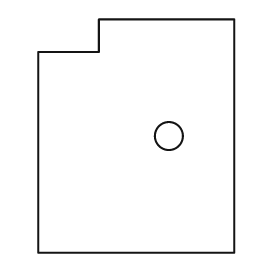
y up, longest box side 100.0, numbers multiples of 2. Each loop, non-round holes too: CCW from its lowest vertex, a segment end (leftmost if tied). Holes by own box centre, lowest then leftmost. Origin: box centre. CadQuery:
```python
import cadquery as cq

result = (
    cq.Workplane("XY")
    .moveTo(-42.0, -50.0)
    .lineTo(42.0, -50.0)
    .lineTo(42.0, 50.0)
    .lineTo(-16.0, 50.0)
    .lineTo(-16.0, 36.0)
    .lineTo(-42.0, 36.0)
    .close()
    .moveTo(14.0, 0.0)
    .circle(6.0)
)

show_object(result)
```